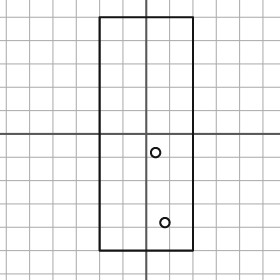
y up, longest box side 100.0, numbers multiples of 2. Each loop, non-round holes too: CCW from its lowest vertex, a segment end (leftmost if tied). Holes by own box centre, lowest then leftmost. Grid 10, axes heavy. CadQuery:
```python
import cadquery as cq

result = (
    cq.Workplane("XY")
    .moveTo(-20.0, -50.0)
    .lineTo(20.0, -50.0)
    .lineTo(20.0, 50.0)
    .lineTo(-20.0, 50.0)
    .close()
    .moveTo(8.0, -38.0)
    .circle(2.0)
    .moveTo(4.0, -8.0)
    .circle(2.0)
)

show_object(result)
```